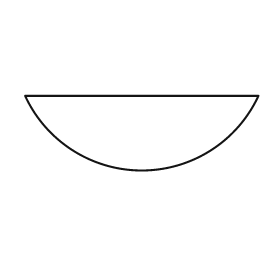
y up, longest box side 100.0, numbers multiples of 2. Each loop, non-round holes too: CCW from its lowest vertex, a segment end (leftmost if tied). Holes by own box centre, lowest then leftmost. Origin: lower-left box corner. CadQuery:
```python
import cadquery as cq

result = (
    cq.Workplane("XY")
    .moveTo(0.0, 32.0)
    .threePointArc((50.0, 0.0), (100.0, 32.0))
    .close()
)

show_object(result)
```